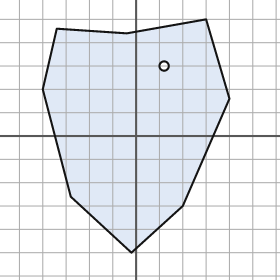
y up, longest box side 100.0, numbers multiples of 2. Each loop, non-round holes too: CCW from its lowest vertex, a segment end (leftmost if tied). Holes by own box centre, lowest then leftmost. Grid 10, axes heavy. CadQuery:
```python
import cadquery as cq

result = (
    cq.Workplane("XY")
    .moveTo(-2.0, -50.0)
    .lineTo(20.0, -30.0)
    .lineTo(40.0, 16.0)
    .lineTo(30.0, 50.0)
    .lineTo(-4.0, 44.0)
    .lineTo(-34.0, 46.0)
    .lineTo(-40.0, 20.0)
    .lineTo(-28.0, -26.0)
    .close()
    .moveTo(12.0, 30.0)
    .circle(2.0)
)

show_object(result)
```